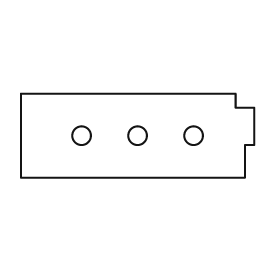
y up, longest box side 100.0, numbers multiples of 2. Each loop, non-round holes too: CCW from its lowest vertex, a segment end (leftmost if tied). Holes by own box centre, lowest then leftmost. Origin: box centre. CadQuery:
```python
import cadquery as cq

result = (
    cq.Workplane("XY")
    .moveTo(-50.0, -18.0)
    .lineTo(46.0, -18.0)
    .lineTo(46.0, -4.0)
    .lineTo(50.0, -4.0)
    .lineTo(50.0, 12.0)
    .lineTo(42.0, 12.0)
    .lineTo(42.0, 18.0)
    .lineTo(-50.0, 18.0)
    .close()
    .moveTo(-24.0, 0.0)
    .circle(4.0)
    .moveTo(0.0, 0.0)
    .circle(4.0)
    .moveTo(24.0, 0.0)
    .circle(4.0)
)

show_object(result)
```